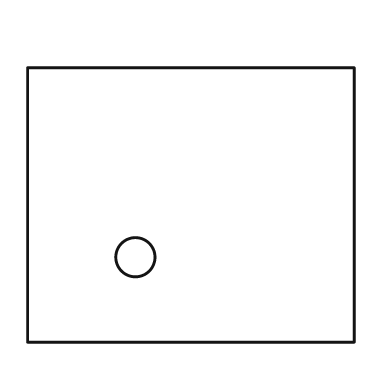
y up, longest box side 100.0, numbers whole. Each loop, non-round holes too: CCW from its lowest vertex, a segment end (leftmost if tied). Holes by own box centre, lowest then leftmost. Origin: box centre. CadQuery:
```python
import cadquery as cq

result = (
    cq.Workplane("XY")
    .moveTo(-50.0, -42.0)
    .lineTo(50.0, -42.0)
    .lineTo(50.0, 42.0)
    .lineTo(-50.0, 42.0)
    .close()
    .moveTo(-17.0, -16.0)
    .circle(6.0)
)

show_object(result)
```